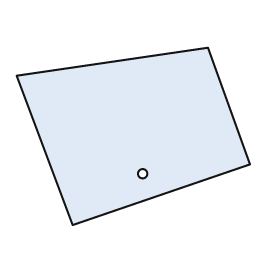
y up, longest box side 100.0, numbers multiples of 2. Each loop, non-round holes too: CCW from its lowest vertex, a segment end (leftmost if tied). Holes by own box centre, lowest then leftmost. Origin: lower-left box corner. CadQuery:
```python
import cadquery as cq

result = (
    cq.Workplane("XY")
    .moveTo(24.0, 0.0)
    .lineTo(100.0, 26.0)
    .lineTo(82.0, 76.0)
    .lineTo(0.0, 64.0)
    .close()
    .moveTo(54.0, 22.0)
    .circle(2.0)
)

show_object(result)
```